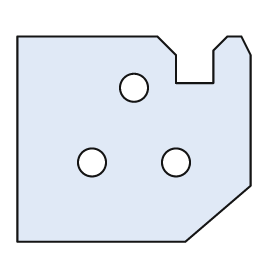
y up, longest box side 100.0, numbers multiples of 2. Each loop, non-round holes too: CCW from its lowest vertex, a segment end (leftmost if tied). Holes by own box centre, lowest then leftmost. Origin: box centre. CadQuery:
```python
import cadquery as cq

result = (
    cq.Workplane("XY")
    .moveTo(-50.0, -44.0)
    .lineTo(22.0, -44.0)
    .lineTo(50.0, -20.0)
    .lineTo(50.0, 36.0)
    .lineTo(46.0, 44.0)
    .lineTo(40.0, 44.0)
    .lineTo(34.0, 38.0)
    .lineTo(34.0, 24.0)
    .lineTo(18.0, 24.0)
    .lineTo(18.0, 36.0)
    .lineTo(10.0, 44.0)
    .lineTo(-50.0, 44.0)
    .close()
    .moveTo(-18.0, -10.0)
    .circle(6.0)
    .moveTo(18.0, -10.0)
    .circle(6.0)
    .moveTo(0.0, 22.0)
    .circle(6.0)
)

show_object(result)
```